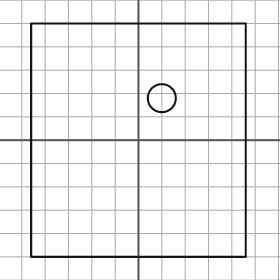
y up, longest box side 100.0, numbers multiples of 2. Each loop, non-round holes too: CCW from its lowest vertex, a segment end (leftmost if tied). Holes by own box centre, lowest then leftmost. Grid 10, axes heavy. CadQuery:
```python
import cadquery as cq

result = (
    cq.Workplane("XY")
    .moveTo(-46.0, -50.0)
    .lineTo(46.0, -50.0)
    .lineTo(46.0, 50.0)
    .lineTo(-46.0, 50.0)
    .close()
    .moveTo(10.0, 18.0)
    .circle(6.0)
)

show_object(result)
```